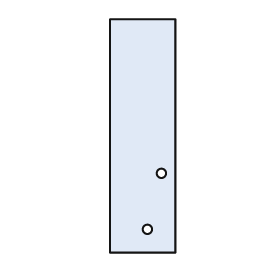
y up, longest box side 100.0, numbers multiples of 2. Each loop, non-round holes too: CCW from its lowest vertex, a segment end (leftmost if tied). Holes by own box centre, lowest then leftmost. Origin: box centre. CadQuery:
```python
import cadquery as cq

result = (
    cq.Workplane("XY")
    .moveTo(-14.0, -50.0)
    .lineTo(14.0, -50.0)
    .lineTo(14.0, 50.0)
    .lineTo(-14.0, 50.0)
    .close()
    .moveTo(2.0, -40.0)
    .circle(2.0)
    .moveTo(8.0, -16.0)
    .circle(2.0)
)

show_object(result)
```